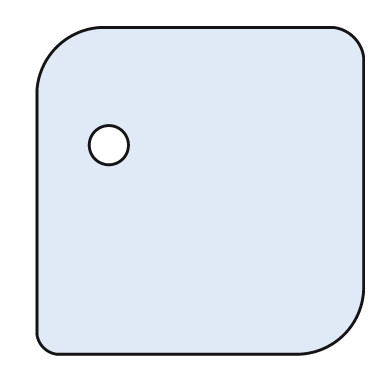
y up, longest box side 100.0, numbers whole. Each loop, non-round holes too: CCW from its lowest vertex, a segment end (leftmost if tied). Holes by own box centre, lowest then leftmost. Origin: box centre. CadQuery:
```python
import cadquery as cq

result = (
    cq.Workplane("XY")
    .moveTo(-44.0, -50.0)
    .lineTo(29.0, -50.0)
    .threePointArc((44.0, -44.0), (50.0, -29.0))
    .lineTo(50.0, 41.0)
    .threePointArc((47.0, 47.0), (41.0, 50.0))
    .lineTo(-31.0, 50.0)
    .threePointArc((-44.0, 44.0), (-50.0, 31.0))
    .lineTo(-50.0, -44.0)
    .threePointArc((-48.0, -48.0), (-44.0, -50.0))
    .close()
    .moveTo(-28.0, 14.0)
    .circle(6.0)
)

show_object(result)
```